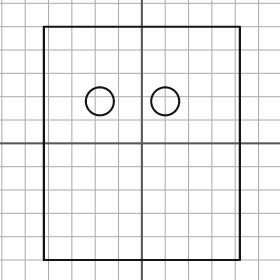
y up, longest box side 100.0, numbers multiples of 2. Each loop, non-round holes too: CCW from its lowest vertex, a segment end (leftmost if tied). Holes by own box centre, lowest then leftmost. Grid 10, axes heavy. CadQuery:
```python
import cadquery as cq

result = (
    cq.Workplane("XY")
    .moveTo(-42.0, -50.0)
    .lineTo(42.0, -50.0)
    .lineTo(42.0, 50.0)
    .lineTo(-42.0, 50.0)
    .close()
    .moveTo(-18.0, 18.0)
    .circle(6.0)
    .moveTo(10.0, 18.0)
    .circle(6.0)
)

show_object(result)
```